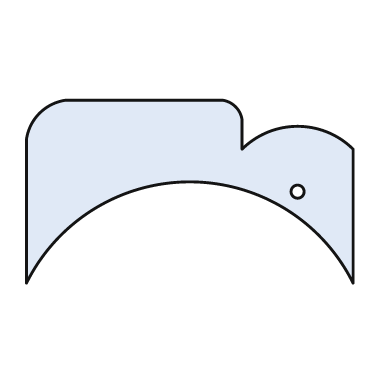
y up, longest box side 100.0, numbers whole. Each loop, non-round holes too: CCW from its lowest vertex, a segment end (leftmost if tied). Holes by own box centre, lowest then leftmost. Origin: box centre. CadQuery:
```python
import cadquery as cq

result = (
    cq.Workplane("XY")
    .moveTo(-50.0, -28.0)
    .threePointArc((0.0, 3.0), (50.0, -28.0))
    .lineTo(50.0, 13.0)
    .threePointArc((33.0, 20.0), (16.0, 13.0))
    .lineTo(16.0, 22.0)
    .threePointArc((14.0, 26.0), (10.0, 28.0))
    .lineTo(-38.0, 28.0)
    .threePointArc((-46.0, 24.0), (-50.0, 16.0))
    .close()
    .moveTo(33.0, 0.0)
    .circle(2.0)
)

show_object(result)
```